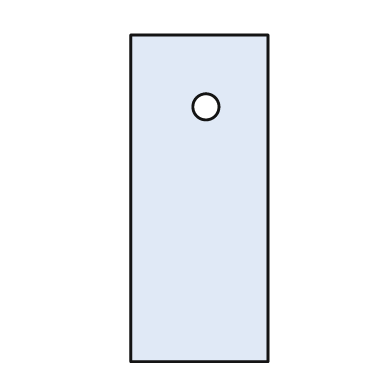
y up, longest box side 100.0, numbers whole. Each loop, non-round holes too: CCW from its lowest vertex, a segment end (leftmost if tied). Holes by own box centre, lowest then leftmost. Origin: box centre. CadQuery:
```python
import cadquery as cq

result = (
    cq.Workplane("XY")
    .moveTo(-21.0, -50.0)
    .lineTo(21.0, -50.0)
    .lineTo(21.0, 50.0)
    .lineTo(-21.0, 50.0)
    .close()
    .moveTo(2.0, 28.0)
    .circle(4.0)
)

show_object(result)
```